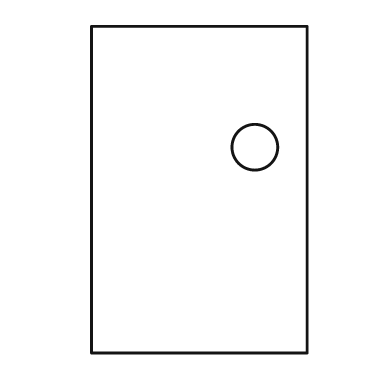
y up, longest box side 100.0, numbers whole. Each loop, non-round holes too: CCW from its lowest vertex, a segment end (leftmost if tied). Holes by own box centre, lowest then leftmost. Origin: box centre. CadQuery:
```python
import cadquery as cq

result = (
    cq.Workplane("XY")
    .moveTo(-33.0, -50.0)
    .lineTo(33.0, -50.0)
    .lineTo(33.0, 50.0)
    .lineTo(-33.0, 50.0)
    .close()
    .moveTo(17.0, 13.0)
    .circle(7.0)
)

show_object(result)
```